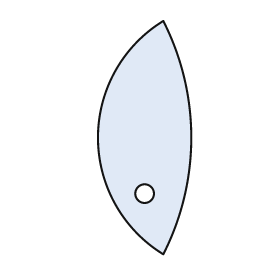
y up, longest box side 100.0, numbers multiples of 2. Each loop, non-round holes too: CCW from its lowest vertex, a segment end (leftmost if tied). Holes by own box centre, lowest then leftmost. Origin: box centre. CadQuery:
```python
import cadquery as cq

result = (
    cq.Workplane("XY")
    .moveTo(8.0, -50.0)
    .threePointArc((20.0, 0.0), (8.0, 50.0))
    .threePointArc((-20.0, 0.0), (8.0, -50.0))
    .close()
    .moveTo(0.0, -24.0)
    .circle(4.0)
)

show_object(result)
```